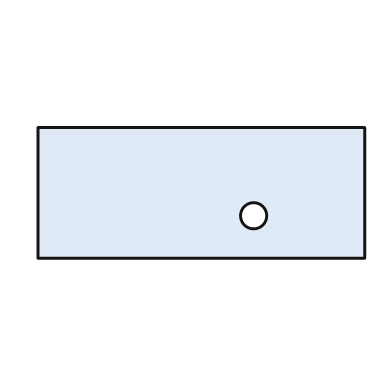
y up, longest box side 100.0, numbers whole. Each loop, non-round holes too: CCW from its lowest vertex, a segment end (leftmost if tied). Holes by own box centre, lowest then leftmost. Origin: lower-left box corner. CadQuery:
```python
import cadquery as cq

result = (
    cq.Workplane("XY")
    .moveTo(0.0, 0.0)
    .lineTo(100.0, 0.0)
    .lineTo(100.0, 40.0)
    .lineTo(0.0, 40.0)
    .close()
    .moveTo(66.0, 13.0)
    .circle(4.0)
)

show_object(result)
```